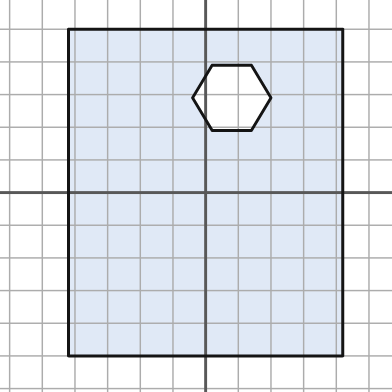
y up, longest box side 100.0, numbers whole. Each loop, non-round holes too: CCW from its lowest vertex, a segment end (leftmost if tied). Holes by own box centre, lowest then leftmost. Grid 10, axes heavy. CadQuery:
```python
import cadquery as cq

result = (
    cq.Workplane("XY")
    .moveTo(-42.0, -50.0)
    .lineTo(42.0, -50.0)
    .lineTo(42.0, 50.0)
    .lineTo(-42.0, 50.0)
    .close()
    .moveTo(2.0, 19.0)
    .lineTo(14.0, 19.0)
    .lineTo(20.0, 29.0)
    .lineTo(14.0, 39.0)
    .lineTo(2.0, 39.0)
    .lineTo(-4.0, 29.0)
    .close()
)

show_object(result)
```